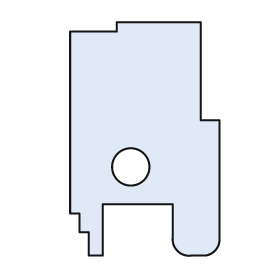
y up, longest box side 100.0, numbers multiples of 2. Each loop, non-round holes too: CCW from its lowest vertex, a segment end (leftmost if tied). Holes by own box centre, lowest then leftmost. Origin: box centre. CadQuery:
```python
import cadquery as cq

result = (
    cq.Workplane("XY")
    .moveTo(-24.0, -50.0)
    .lineTo(-18.0, -50.0)
    .lineTo(-18.0, -28.0)
    .lineTo(12.0, -28.0)
    .lineTo(12.0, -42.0)
    .threePointArc((14.0, -48.0), (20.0, -50.0))
    .lineTo(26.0, -50.0)
    .threePointArc((30.0, -48.0), (32.0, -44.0))
    .lineTo(32.0, 8.0)
    .lineTo(24.0, 8.0)
    .lineTo(24.0, 50.0)
    .lineTo(-12.0, 50.0)
    .lineTo(-12.0, 46.0)
    .lineTo(-32.0, 46.0)
    .lineTo(-32.0, -32.0)
    .lineTo(-28.0, -32.0)
    .lineTo(-28.0, -40.0)
    .lineTo(-24.0, -40.0)
    .close()
    .moveTo(-6.0, -12.0)
    .circle(8.0)
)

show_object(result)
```